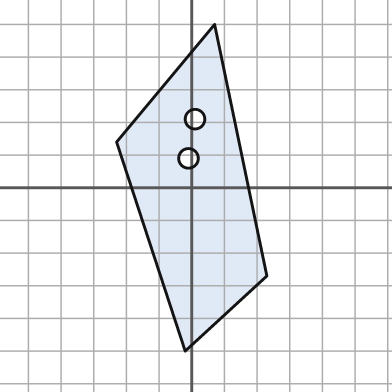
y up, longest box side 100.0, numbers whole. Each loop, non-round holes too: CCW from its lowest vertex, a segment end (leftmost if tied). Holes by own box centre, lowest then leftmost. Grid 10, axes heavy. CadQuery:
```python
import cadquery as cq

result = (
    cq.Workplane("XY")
    .moveTo(-2.0, -50.0)
    .lineTo(23.0, -27.0)
    .lineTo(7.0, 50.0)
    .lineTo(-23.0, 14.0)
    .close()
    .moveTo(-1.0, 9.0)
    .circle(3.0)
    .moveTo(1.0, 21.0)
    .circle(3.0)
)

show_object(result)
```